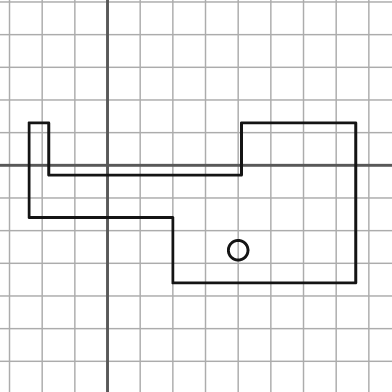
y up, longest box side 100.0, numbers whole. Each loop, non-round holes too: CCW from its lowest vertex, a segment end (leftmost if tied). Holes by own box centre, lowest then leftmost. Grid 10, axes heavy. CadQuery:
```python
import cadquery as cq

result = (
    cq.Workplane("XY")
    .moveTo(20.0, -36.0)
    .lineTo(76.0, -36.0)
    .lineTo(76.0, 13.0)
    .lineTo(41.0, 13.0)
    .lineTo(41.0, -3.0)
    .lineTo(-18.0, -3.0)
    .lineTo(-18.0, 13.0)
    .lineTo(-24.0, 13.0)
    .lineTo(-24.0, -16.0)
    .lineTo(20.0, -16.0)
    .close()
    .moveTo(40.0, -26.0)
    .circle(3.0)
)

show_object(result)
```